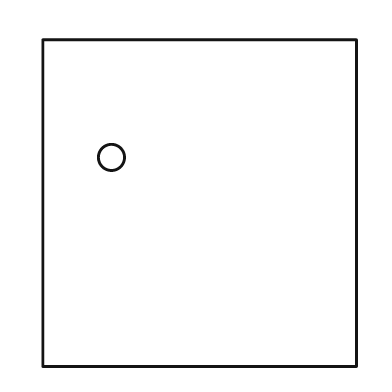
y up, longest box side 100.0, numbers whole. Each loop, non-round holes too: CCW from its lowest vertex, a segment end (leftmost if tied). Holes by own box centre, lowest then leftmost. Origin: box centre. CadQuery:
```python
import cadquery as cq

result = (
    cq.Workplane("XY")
    .moveTo(-48.0, -50.0)
    .lineTo(48.0, -50.0)
    .lineTo(48.0, 50.0)
    .lineTo(-48.0, 50.0)
    .close()
    .moveTo(-27.0, 14.0)
    .circle(4.0)
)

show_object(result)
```